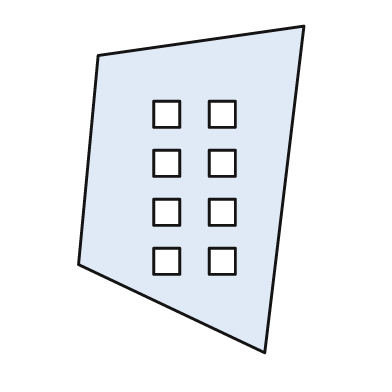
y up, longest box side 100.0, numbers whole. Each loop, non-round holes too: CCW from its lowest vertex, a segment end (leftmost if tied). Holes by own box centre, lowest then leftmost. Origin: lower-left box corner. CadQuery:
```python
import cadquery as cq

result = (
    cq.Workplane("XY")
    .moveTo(57.0, 0.0)
    .lineTo(69.0, 100.0)
    .lineTo(6.0, 91.0)
    .lineTo(0.0, 27.0)
    .close()
    .moveTo(23.0, 24.0)
    .lineTo(31.0, 24.0)
    .lineTo(31.0, 32.0)
    .lineTo(23.0, 32.0)
    .close()
    .moveTo(40.0, 24.0)
    .lineTo(48.0, 24.0)
    .lineTo(48.0, 32.0)
    .lineTo(40.0, 32.0)
    .close()
    .moveTo(23.0, 39.0)
    .lineTo(31.0, 39.0)
    .lineTo(31.0, 47.0)
    .lineTo(23.0, 47.0)
    .close()
    .moveTo(40.0, 39.0)
    .lineTo(48.0, 39.0)
    .lineTo(48.0, 47.0)
    .lineTo(40.0, 47.0)
    .close()
    .moveTo(23.0, 54.0)
    .lineTo(31.0, 54.0)
    .lineTo(31.0, 62.0)
    .lineTo(23.0, 62.0)
    .close()
    .moveTo(40.0, 54.0)
    .lineTo(48.0, 54.0)
    .lineTo(48.0, 62.0)
    .lineTo(40.0, 62.0)
    .close()
    .moveTo(23.0, 69.0)
    .lineTo(31.0, 69.0)
    .lineTo(31.0, 77.0)
    .lineTo(23.0, 77.0)
    .close()
    .moveTo(40.0, 69.0)
    .lineTo(48.0, 69.0)
    .lineTo(48.0, 77.0)
    .lineTo(40.0, 77.0)
    .close()
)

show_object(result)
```